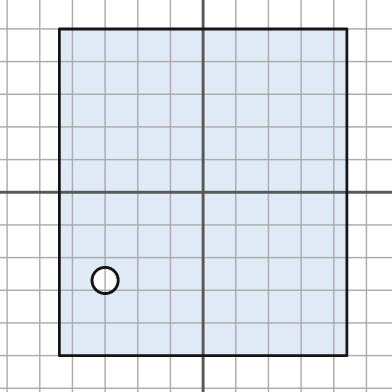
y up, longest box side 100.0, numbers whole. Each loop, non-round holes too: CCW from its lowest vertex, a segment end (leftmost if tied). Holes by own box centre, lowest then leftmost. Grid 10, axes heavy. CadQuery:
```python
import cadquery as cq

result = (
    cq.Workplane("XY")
    .moveTo(-44.0, -50.0)
    .lineTo(44.0, -50.0)
    .lineTo(44.0, 50.0)
    .lineTo(-44.0, 50.0)
    .close()
    .moveTo(-30.0, -27.0)
    .circle(4.0)
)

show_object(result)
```